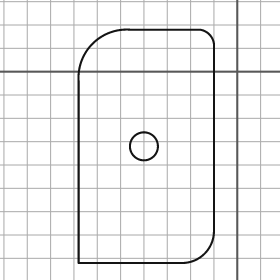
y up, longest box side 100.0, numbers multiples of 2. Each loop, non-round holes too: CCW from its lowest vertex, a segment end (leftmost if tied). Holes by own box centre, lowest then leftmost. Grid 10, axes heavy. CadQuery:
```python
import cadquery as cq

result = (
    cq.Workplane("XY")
    .moveTo(-68.0, -82.0)
    .lineTo(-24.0, -82.0)
    .threePointArc((-14.0, -78.0), (-10.0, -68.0))
    .lineTo(-10.0, 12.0)
    .threePointArc((-12.0, 16.0), (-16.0, 18.0))
    .lineTo(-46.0, 18.0)
    .threePointArc((-62.0, 12.0), (-68.0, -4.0))
    .close()
    .moveTo(-40.0, -32.0)
    .circle(6.0)
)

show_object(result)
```